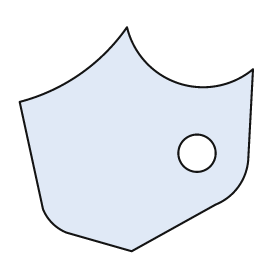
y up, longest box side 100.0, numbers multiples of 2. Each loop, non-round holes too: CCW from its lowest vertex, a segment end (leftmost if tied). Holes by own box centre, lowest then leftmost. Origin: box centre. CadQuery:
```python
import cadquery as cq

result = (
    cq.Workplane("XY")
    .moveTo(-2.0, -48.0)
    .lineTo(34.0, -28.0)
    .threePointArc((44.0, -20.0), (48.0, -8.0))
    .lineTo(50.0, 30.0)
    .threePointArc((18.0, 24.0), (-4.0, 48.0))
    .threePointArc((-24.0, 28.0), (-50.0, 16.0))
    .lineTo(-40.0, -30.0)
    .threePointArc((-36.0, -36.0), (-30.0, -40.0))
    .close()
    .moveTo(26.0, -6.0)
    .circle(8.0)
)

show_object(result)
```